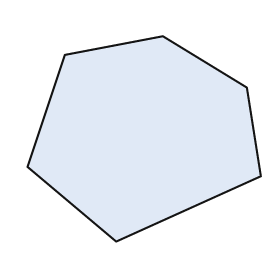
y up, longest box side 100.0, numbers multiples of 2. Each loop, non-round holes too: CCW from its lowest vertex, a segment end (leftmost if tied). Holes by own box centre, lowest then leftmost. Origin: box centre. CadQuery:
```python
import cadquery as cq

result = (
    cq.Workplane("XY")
    .moveTo(-12.0, -44.0)
    .lineTo(50.0, -16.0)
    .lineTo(44.0, 22.0)
    .lineTo(8.0, 44.0)
    .lineTo(-34.0, 36.0)
    .lineTo(-50.0, -12.0)
    .close()
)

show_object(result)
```